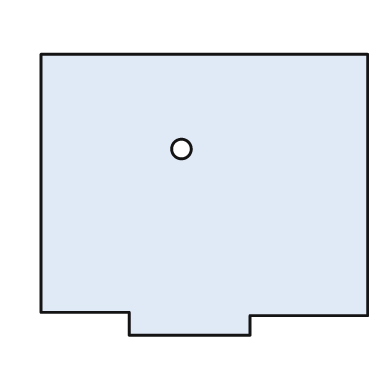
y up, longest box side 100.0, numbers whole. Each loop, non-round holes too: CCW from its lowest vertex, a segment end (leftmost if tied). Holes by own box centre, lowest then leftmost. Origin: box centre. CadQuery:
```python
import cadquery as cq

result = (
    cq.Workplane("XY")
    .moveTo(-23.0, -43.0)
    .lineTo(14.0, -43.0)
    .lineTo(14.0, -37.0)
    .lineTo(50.0, -37.0)
    .lineTo(50.0, 43.0)
    .lineTo(-50.0, 43.0)
    .lineTo(-50.0, -36.0)
    .lineTo(-23.0, -36.0)
    .close()
    .moveTo(-7.0, 14.0)
    .circle(3.0)
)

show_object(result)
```